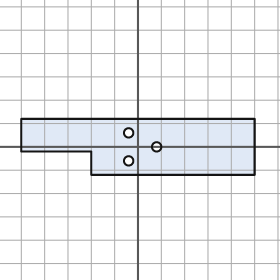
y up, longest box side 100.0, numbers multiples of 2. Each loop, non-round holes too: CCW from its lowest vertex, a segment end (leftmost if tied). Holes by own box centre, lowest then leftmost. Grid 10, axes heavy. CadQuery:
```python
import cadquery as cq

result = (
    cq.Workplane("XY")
    .moveTo(-20.0, -12.0)
    .lineTo(50.0, -12.0)
    .lineTo(50.0, 12.0)
    .lineTo(-50.0, 12.0)
    .lineTo(-50.0, -2.0)
    .lineTo(-20.0, -2.0)
    .close()
    .moveTo(-4.0, -6.0)
    .circle(2.0)
    .moveTo(8.0, 0.0)
    .circle(2.0)
    .moveTo(-4.0, 6.0)
    .circle(2.0)
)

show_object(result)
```